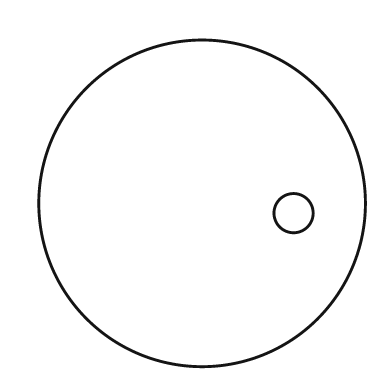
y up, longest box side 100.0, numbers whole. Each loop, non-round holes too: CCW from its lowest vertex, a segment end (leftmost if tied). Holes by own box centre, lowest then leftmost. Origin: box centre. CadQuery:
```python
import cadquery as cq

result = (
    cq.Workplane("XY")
    .moveTo(0.0, 0.0)
    .circle(50.0)
    .moveTo(28.0, -3.0)
    .circle(6.0)
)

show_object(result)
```